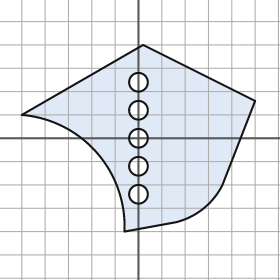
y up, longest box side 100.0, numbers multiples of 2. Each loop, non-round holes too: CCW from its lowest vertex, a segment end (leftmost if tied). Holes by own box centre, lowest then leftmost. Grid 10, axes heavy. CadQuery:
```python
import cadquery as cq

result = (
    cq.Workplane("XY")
    .moveTo(-6.0, -40.0)
    .lineTo(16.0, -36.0)
    .threePointArc((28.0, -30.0), (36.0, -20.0))
    .lineTo(50.0, 16.0)
    .lineTo(2.0, 40.0)
    .lineTo(-50.0, 10.0)
    .threePointArc((-18.0, -6.0), (-6.0, -40.0))
    .close()
    .moveTo(0.0, -24.0)
    .circle(4.0)
    .moveTo(0.0, -12.0)
    .circle(4.0)
    .moveTo(0.0, 0.0)
    .circle(4.0)
    .moveTo(0.0, 12.0)
    .circle(4.0)
    .moveTo(0.0, 24.0)
    .circle(4.0)
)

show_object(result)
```